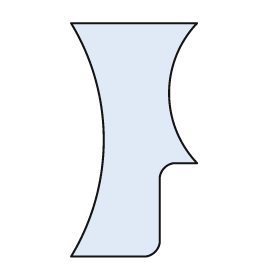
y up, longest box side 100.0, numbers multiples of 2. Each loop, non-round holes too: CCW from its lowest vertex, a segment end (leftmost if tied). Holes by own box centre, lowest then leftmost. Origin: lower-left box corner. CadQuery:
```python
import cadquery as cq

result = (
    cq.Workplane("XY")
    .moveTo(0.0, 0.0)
    .lineTo(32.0, 0.0)
    .threePointArc((36.0, 2.0), (38.0, 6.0))
    .lineTo(38.0, 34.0)
    .threePointArc((40.0, 38.0), (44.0, 40.0))
    .lineTo(54.0, 40.0)
    .threePointArc((42.0, 70.0), (54.0, 100.0))
    .lineTo(0.0, 100.0)
    .threePointArc((14.0, 50.0), (0.0, 0.0))
    .close()
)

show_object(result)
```